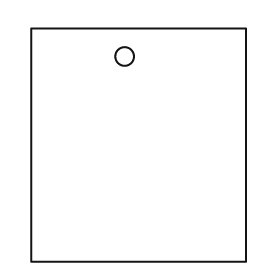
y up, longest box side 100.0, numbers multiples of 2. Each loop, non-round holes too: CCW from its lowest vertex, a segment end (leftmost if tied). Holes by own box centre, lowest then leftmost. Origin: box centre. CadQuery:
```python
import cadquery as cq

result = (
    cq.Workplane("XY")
    .moveTo(-46.0, -50.0)
    .lineTo(46.0, -50.0)
    .lineTo(46.0, 50.0)
    .lineTo(-46.0, 50.0)
    .close()
    .moveTo(-6.0, 38.0)
    .circle(4.0)
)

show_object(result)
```